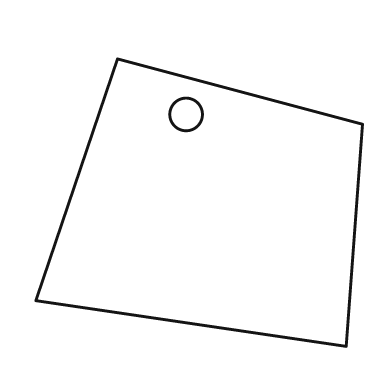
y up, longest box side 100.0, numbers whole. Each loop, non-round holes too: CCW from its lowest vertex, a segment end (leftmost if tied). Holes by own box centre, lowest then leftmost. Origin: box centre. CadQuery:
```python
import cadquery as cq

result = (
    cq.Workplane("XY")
    .moveTo(45.0, -44.0)
    .lineTo(50.0, 24.0)
    .lineTo(-25.0, 44.0)
    .lineTo(-50.0, -30.0)
    .close()
    .moveTo(-4.0, 27.0)
    .circle(5.0)
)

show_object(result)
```